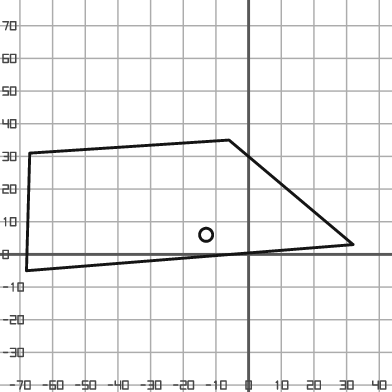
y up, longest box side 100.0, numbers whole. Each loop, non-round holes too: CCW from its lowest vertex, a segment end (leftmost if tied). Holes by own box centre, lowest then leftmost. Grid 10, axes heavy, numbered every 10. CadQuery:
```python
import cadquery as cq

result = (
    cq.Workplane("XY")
    .moveTo(-68.0, -5.0)
    .lineTo(32.0, 3.0)
    .lineTo(-6.0, 35.0)
    .lineTo(-67.0, 31.0)
    .close()
    .moveTo(-13.0, 6.0)
    .circle(2.0)
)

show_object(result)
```